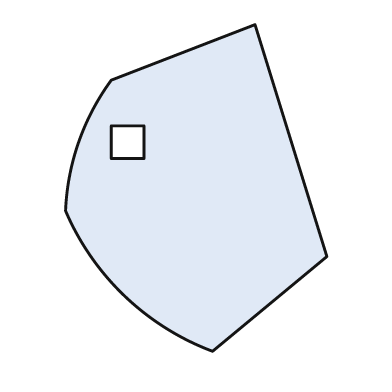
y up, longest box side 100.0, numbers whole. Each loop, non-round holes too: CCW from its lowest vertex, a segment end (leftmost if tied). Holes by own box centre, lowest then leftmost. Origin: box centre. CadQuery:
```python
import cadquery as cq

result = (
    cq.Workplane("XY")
    .moveTo(5.0, -50.0)
    .lineTo(40.0, -21.0)
    .lineTo(18.0, 50.0)
    .lineTo(-26.0, 33.0)
    .threePointArc((-36.0, 14.0), (-40.0, -7.0))
    .threePointArc((-22.0, -33.0), (5.0, -50.0))
    .close()
    .moveTo(-26.0, 9.0)
    .lineTo(-16.0, 9.0)
    .lineTo(-16.0, 19.0)
    .lineTo(-26.0, 19.0)
    .close()
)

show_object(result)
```